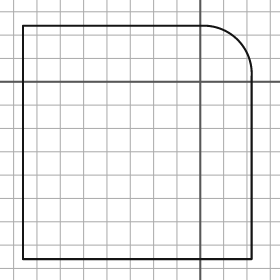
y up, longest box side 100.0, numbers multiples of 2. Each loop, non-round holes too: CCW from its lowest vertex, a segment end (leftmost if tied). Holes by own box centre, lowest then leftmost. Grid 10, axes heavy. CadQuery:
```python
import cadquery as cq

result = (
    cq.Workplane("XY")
    .moveTo(-76.0, -76.0)
    .lineTo(22.0, -76.0)
    .lineTo(22.0, 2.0)
    .threePointArc((16.0, 18.0), (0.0, 24.0))
    .lineTo(-76.0, 24.0)
    .close()
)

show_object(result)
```